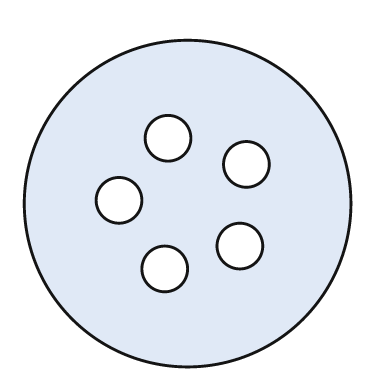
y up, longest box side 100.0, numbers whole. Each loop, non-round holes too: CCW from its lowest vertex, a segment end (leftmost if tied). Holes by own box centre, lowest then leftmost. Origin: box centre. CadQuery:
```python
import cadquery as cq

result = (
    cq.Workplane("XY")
    .moveTo(0.0, 0.0)
    .circle(50.0)
    .moveTo(-7.0, -20.0)
    .circle(7.0)
    .moveTo(16.0, -13.0)
    .circle(7.0)
    .moveTo(-21.0, 1.0)
    .circle(7.0)
    .moveTo(18.0, 12.0)
    .circle(7.0)
    .moveTo(-6.0, 20.0)
    .circle(7.0)
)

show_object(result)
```